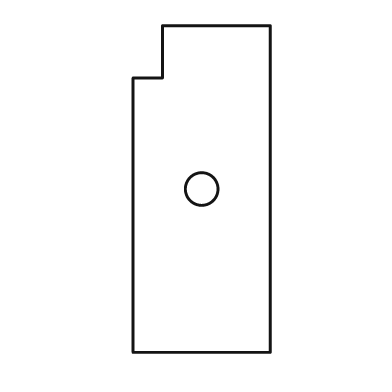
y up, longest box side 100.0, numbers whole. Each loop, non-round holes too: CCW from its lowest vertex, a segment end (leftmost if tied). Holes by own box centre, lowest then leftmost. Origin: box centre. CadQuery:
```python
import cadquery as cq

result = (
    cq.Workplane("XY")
    .moveTo(-21.0, -50.0)
    .lineTo(21.0, -50.0)
    .lineTo(21.0, 50.0)
    .lineTo(-12.0, 50.0)
    .lineTo(-12.0, 34.0)
    .lineTo(-21.0, 34.0)
    .close()
    .moveTo(0.0, 0.0)
    .circle(5.0)
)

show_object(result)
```